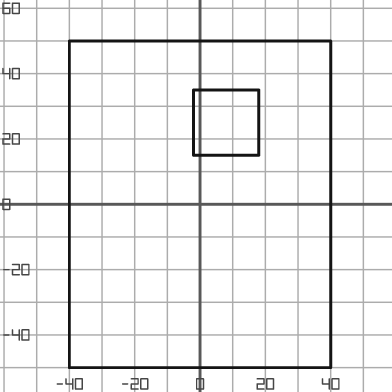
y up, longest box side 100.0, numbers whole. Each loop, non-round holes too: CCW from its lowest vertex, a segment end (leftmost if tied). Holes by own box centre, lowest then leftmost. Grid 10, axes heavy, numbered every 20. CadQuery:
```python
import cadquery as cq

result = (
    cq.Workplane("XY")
    .moveTo(-40.0, -50.0)
    .lineTo(40.0, -50.0)
    .lineTo(40.0, 50.0)
    .lineTo(-40.0, 50.0)
    .close()
    .moveTo(-2.0, 15.0)
    .lineTo(18.0, 15.0)
    .lineTo(18.0, 35.0)
    .lineTo(-2.0, 35.0)
    .close()
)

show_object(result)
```